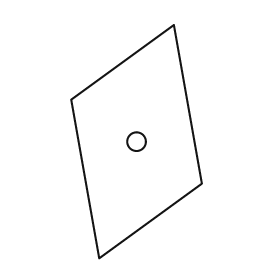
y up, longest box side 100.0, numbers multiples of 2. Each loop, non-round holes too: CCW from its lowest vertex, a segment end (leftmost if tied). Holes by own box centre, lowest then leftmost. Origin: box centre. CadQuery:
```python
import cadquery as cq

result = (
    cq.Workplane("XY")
    .moveTo(-16.0, -50.0)
    .lineTo(28.0, -18.0)
    .lineTo(16.0, 50.0)
    .lineTo(-28.0, 18.0)
    .close()
    .moveTo(0.0, 0.0)
    .circle(4.0)
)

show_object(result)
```